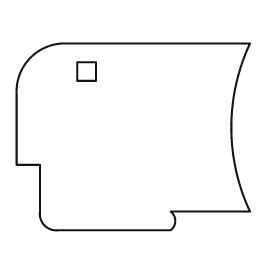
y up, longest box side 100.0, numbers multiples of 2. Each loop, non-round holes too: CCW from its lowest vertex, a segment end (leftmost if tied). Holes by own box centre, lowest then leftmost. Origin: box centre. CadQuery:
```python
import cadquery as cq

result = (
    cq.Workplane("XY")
    .moveTo(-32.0, -40.0)
    .lineTo(16.0, -40.0)
    .threePointArc((18.0, -36.0), (16.0, -32.0))
    .lineTo(50.0, -32.0)
    .threePointArc((42.0, 4.0), (50.0, 40.0))
    .lineTo(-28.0, 40.0)
    .threePointArc((-44.0, 34.0), (-50.0, 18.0))
    .lineTo(-50.0, -12.0)
    .lineTo(-40.0, -12.0)
    .lineTo(-40.0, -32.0)
    .threePointArc((-38.0, -38.0), (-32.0, -40.0))
    .close()
    .moveTo(-24.0, 24.0)
    .lineTo(-16.0, 24.0)
    .lineTo(-16.0, 32.0)
    .lineTo(-24.0, 32.0)
    .close()
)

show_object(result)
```